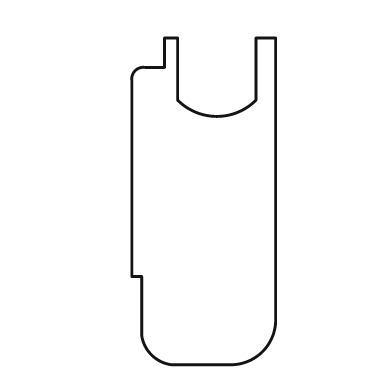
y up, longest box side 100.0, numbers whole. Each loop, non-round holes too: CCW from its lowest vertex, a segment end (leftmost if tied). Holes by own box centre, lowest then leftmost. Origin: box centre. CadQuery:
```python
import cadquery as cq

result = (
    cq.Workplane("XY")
    .moveTo(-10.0, -50.0)
    .lineTo(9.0, -50.0)
    .threePointArc((18.0, -46.0), (22.0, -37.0))
    .lineTo(22.0, 50.0)
    .lineTo(16.0, 50.0)
    .lineTo(16.0, 31.0)
    .threePointArc((4.0, 26.0), (-8.0, 31.0))
    .lineTo(-8.0, 50.0)
    .lineTo(-12.0, 50.0)
    .lineTo(-12.0, 41.0)
    .lineTo(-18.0, 41.0)
    .threePointArc((-21.0, 40.0), (-22.0, 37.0))
    .lineTo(-22.0, -23.0)
    .lineTo(-19.0, -23.0)
    .lineTo(-19.0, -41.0)
    .threePointArc((-16.0, -47.0), (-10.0, -50.0))
    .close()
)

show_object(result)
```